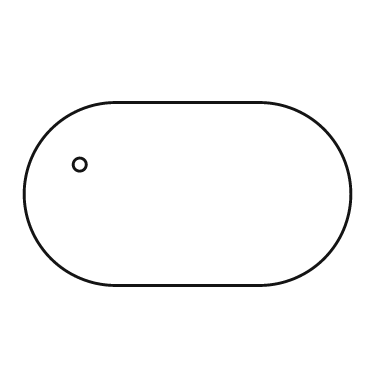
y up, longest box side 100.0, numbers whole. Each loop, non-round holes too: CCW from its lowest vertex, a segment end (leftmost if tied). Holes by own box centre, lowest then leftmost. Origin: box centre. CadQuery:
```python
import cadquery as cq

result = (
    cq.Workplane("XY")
    .moveTo(-22.0, -28.0)
    .lineTo(22.0, -28.0)
    .threePointArc((50.0, 0.0), (22.0, 28.0))
    .lineTo(-22.0, 28.0)
    .threePointArc((-50.0, 0.0), (-22.0, -28.0))
    .close()
    .moveTo(-33.0, 9.0)
    .circle(2.0)
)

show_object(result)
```